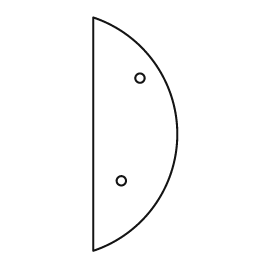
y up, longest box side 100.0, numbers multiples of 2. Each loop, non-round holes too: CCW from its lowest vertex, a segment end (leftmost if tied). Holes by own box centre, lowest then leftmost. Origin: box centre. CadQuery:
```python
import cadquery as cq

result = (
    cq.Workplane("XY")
    .moveTo(-18.0, -50.0)
    .threePointArc((18.0, 0.0), (-18.0, 50.0))
    .close()
    .moveTo(-6.0, -20.0)
    .circle(2.0)
    .moveTo(2.0, 24.0)
    .circle(2.0)
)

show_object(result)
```